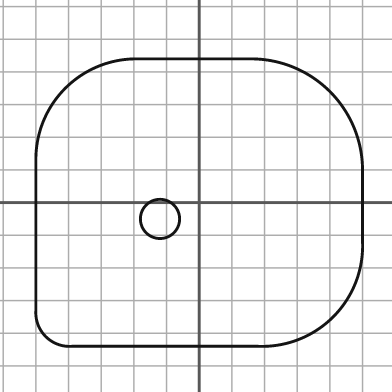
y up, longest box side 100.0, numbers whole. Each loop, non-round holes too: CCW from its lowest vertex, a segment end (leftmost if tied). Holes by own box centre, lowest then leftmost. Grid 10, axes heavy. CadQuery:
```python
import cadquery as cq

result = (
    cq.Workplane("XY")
    .moveTo(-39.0, -44.0)
    .lineTo(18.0, -44.0)
    .threePointArc((41.0, -35.0), (50.0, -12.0))
    .lineTo(50.0, 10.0)
    .threePointArc((40.0, 34.0), (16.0, 44.0))
    .lineTo(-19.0, 44.0)
    .threePointArc((-41.0, 35.0), (-50.0, 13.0))
    .lineTo(-50.0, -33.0)
    .threePointArc((-47.0, -41.0), (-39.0, -44.0))
    .close()
    .moveTo(-12.0, -5.0)
    .circle(6.0)
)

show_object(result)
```